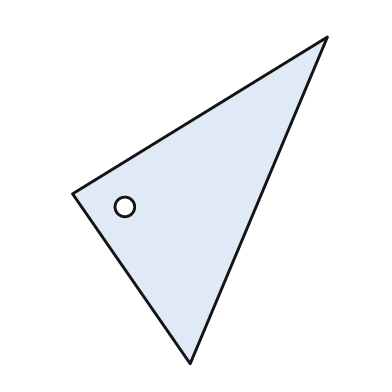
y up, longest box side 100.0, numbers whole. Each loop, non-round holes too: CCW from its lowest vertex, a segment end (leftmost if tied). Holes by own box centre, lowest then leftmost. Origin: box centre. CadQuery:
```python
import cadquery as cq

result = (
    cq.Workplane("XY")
    .moveTo(-3.0, -50.0)
    .lineTo(39.0, 50.0)
    .lineTo(-39.0, 2.0)
    .close()
    .moveTo(-23.0, -2.0)
    .circle(3.0)
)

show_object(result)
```